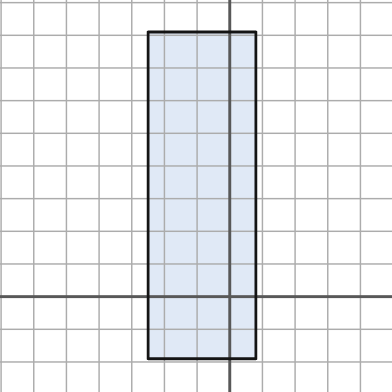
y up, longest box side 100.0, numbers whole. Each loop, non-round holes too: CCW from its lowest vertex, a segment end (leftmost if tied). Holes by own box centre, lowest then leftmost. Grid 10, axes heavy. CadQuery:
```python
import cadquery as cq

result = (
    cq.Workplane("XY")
    .moveTo(-25.0, -19.0)
    .lineTo(8.0, -19.0)
    .lineTo(8.0, 81.0)
    .lineTo(-25.0, 81.0)
    .close()
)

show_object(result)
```